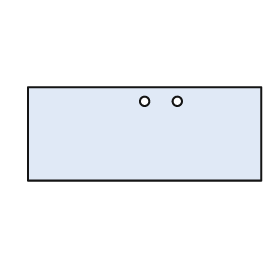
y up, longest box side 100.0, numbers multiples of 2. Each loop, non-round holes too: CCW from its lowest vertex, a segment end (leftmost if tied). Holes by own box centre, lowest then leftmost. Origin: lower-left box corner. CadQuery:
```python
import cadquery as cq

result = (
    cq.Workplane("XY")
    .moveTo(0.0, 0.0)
    .lineTo(100.0, 0.0)
    .lineTo(100.0, 40.0)
    .lineTo(0.0, 40.0)
    .close()
    .moveTo(50.0, 34.0)
    .circle(2.0)
    .moveTo(64.0, 34.0)
    .circle(2.0)
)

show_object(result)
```